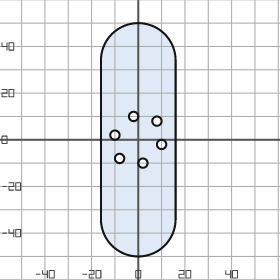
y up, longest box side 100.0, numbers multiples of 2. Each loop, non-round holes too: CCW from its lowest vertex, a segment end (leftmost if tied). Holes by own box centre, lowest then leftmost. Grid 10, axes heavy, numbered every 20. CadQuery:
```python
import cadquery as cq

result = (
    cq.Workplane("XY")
    .moveTo(-16.0, -34.0)
    .threePointArc((0.0, -50.0), (16.0, -34.0))
    .lineTo(16.0, 34.0)
    .threePointArc((0.0, 50.0), (-16.0, 34.0))
    .close()
    .moveTo(2.0, -10.0)
    .circle(2.0)
    .moveTo(-8.0, -8.0)
    .circle(2.0)
    .moveTo(10.0, -2.0)
    .circle(2.0)
    .moveTo(-10.0, 2.0)
    .circle(2.0)
    .moveTo(8.0, 8.0)
    .circle(2.0)
    .moveTo(-2.0, 10.0)
    .circle(2.0)
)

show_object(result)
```